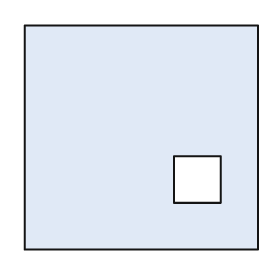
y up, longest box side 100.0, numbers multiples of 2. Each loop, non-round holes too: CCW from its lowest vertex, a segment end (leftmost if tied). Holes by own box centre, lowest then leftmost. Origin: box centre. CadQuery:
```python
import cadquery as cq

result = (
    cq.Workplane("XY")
    .moveTo(-50.0, -48.0)
    .lineTo(50.0, -48.0)
    .lineTo(50.0, 48.0)
    .lineTo(-50.0, 48.0)
    .close()
    .moveTo(14.0, -28.0)
    .lineTo(34.0, -28.0)
    .lineTo(34.0, -8.0)
    .lineTo(14.0, -8.0)
    .close()
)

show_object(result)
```